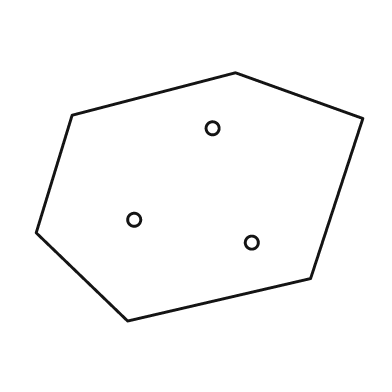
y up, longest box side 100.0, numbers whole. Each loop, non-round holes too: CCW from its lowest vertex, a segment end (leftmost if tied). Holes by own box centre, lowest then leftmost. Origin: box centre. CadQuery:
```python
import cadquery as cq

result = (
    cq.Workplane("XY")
    .moveTo(-22.0, -38.0)
    .lineTo(34.0, -25.0)
    .lineTo(50.0, 24.0)
    .lineTo(11.0, 38.0)
    .lineTo(-39.0, 25.0)
    .lineTo(-50.0, -11.0)
    .close()
    .moveTo(16.0, -14.0)
    .circle(2.0)
    .moveTo(-20.0, -7.0)
    .circle(2.0)
    .moveTo(4.0, 21.0)
    .circle(2.0)
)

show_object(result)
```